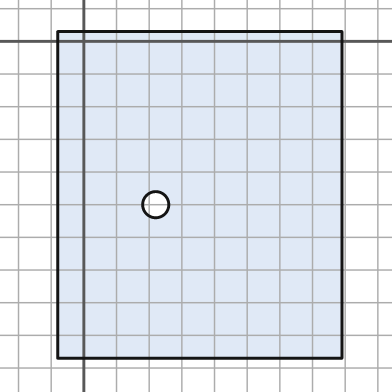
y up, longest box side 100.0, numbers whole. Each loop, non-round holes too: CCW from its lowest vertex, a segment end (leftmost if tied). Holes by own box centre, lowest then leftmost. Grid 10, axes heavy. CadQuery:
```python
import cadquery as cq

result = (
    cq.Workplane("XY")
    .moveTo(-8.0, -97.0)
    .lineTo(79.0, -97.0)
    .lineTo(79.0, 3.0)
    .lineTo(-8.0, 3.0)
    .close()
    .moveTo(22.0, -50.0)
    .circle(4.0)
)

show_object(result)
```